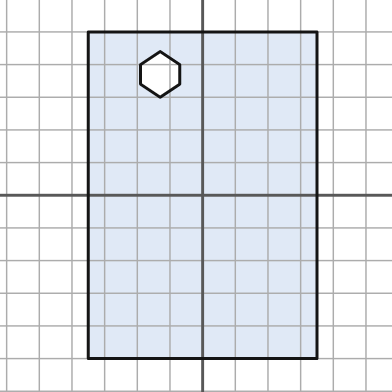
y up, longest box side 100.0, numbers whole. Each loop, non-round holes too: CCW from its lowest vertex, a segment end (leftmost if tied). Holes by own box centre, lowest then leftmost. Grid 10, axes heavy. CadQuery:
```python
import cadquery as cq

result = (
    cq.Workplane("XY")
    .moveTo(-35.0, -50.0)
    .lineTo(35.0, -50.0)
    .lineTo(35.0, 50.0)
    .lineTo(-35.0, 50.0)
    .close()
    .moveTo(-13.0, 30.0)
    .lineTo(-7.0, 34.0)
    .lineTo(-7.0, 40.0)
    .lineTo(-13.0, 44.0)
    .lineTo(-19.0, 40.0)
    .lineTo(-19.0, 34.0)
    .close()
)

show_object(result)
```